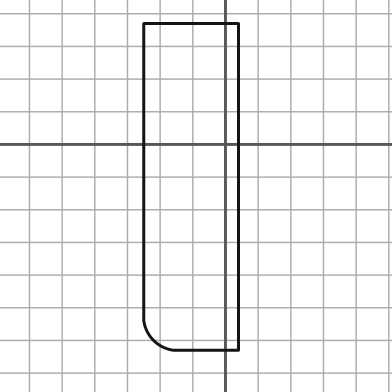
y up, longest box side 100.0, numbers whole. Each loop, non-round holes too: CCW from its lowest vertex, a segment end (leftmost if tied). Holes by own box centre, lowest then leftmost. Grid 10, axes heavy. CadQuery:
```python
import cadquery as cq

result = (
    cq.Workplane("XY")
    .moveTo(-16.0, -63.0)
    .lineTo(4.0, -63.0)
    .lineTo(4.0, 37.0)
    .lineTo(-25.0, 37.0)
    .lineTo(-25.0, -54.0)
    .threePointArc((-22.0, -60.0), (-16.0, -63.0))
    .close()
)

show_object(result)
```